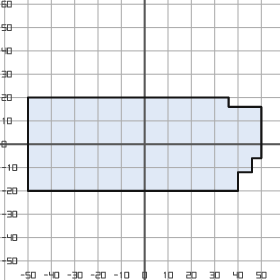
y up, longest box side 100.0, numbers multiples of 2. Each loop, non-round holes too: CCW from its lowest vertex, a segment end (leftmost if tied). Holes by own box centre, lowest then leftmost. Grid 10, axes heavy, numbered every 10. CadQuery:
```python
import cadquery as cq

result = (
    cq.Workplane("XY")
    .moveTo(-50.0, -20.0)
    .lineTo(40.0, -20.0)
    .lineTo(40.0, -12.0)
    .lineTo(46.0, -12.0)
    .lineTo(46.0, -6.0)
    .lineTo(50.0, -6.0)
    .lineTo(50.0, 16.0)
    .lineTo(36.0, 16.0)
    .lineTo(36.0, 20.0)
    .lineTo(-50.0, 20.0)
    .close()
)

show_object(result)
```